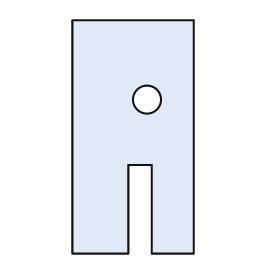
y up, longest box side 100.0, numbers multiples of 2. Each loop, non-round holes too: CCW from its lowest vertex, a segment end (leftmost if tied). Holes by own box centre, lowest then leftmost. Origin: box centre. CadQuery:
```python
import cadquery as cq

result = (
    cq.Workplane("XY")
    .moveTo(-26.0, -50.0)
    .lineTo(-2.0, -50.0)
    .lineTo(-2.0, -12.0)
    .lineTo(8.0, -12.0)
    .lineTo(8.0, -50.0)
    .lineTo(26.0, -50.0)
    .lineTo(26.0, 50.0)
    .lineTo(-26.0, 50.0)
    .close()
    .moveTo(6.0, 16.0)
    .circle(6.0)
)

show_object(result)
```